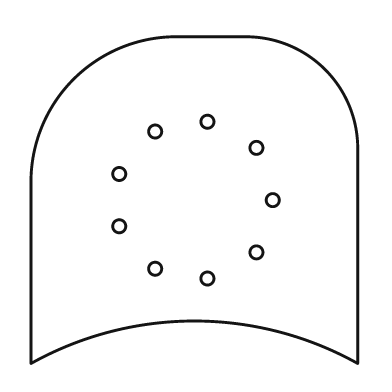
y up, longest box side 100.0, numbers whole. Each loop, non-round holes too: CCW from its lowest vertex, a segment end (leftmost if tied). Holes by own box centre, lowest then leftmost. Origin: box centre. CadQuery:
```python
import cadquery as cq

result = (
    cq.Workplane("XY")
    .moveTo(-50.0, -50.0)
    .threePointArc((0.0, -37.0), (50.0, -50.0))
    .lineTo(50.0, 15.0)
    .threePointArc((40.0, 40.0), (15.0, 50.0))
    .lineTo(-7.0, 50.0)
    .threePointArc((-37.0, 37.0), (-50.0, 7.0))
    .close()
    .moveTo(4.0, -24.0)
    .circle(2.0)
    .moveTo(-12.0, -21.0)
    .circle(2.0)
    .moveTo(19.0, -16.0)
    .circle(2.0)
    .moveTo(-23.0, -8.0)
    .circle(2.0)
    .moveTo(24.0, 0.0)
    .circle(2.0)
    .moveTo(-23.0, 8.0)
    .circle(2.0)
    .moveTo(19.0, 16.0)
    .circle(2.0)
    .moveTo(-12.0, 21.0)
    .circle(2.0)
    .moveTo(4.0, 24.0)
    .circle(2.0)
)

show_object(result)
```